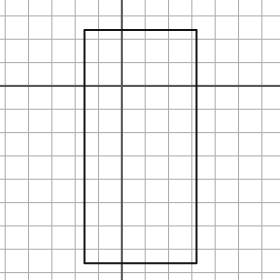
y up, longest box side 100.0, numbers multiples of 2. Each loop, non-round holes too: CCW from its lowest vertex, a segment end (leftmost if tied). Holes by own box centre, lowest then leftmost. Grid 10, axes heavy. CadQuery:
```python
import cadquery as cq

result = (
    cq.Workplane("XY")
    .moveTo(-16.0, -76.0)
    .lineTo(32.0, -76.0)
    .lineTo(32.0, 24.0)
    .lineTo(-16.0, 24.0)
    .close()
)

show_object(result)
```